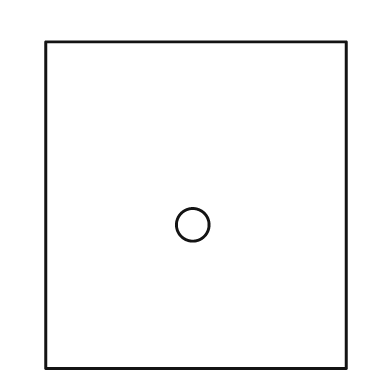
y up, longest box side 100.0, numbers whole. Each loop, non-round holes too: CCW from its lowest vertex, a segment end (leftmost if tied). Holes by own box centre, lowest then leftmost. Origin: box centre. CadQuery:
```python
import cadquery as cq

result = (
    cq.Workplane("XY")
    .moveTo(-46.0, -50.0)
    .lineTo(46.0, -50.0)
    .lineTo(46.0, 50.0)
    .lineTo(-46.0, 50.0)
    .close()
    .moveTo(-1.0, -6.0)
    .circle(5.0)
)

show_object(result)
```